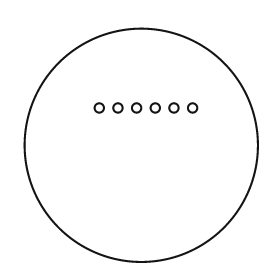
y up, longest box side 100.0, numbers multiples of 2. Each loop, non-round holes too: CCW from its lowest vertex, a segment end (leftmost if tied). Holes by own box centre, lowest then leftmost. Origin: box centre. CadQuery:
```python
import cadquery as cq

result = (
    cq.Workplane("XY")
    .moveTo(0.0, 0.0)
    .circle(50.0)
    .moveTo(-18.0, 16.0)
    .circle(2.0)
    .moveTo(-10.0, 16.0)
    .circle(2.0)
    .moveTo(-2.0, 16.0)
    .circle(2.0)
    .moveTo(6.0, 16.0)
    .circle(2.0)
    .moveTo(14.0, 16.0)
    .circle(2.0)
    .moveTo(22.0, 16.0)
    .circle(2.0)
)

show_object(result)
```